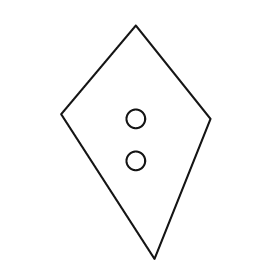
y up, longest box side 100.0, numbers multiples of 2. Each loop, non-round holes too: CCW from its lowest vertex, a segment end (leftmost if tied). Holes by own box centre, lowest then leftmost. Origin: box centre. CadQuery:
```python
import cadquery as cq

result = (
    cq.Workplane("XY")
    .moveTo(8.0, -50.0)
    .lineTo(32.0, 10.0)
    .lineTo(0.0, 50.0)
    .lineTo(-32.0, 12.0)
    .close()
    .moveTo(0.0, -8.0)
    .circle(4.0)
    .moveTo(0.0, 10.0)
    .circle(4.0)
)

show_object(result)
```